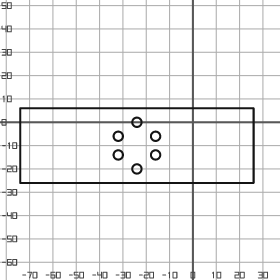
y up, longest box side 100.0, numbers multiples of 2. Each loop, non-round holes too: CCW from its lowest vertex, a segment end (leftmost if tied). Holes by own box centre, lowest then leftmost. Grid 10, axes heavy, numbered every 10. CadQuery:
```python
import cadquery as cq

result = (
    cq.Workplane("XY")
    .moveTo(-74.0, -26.0)
    .lineTo(26.0, -26.0)
    .lineTo(26.0, 6.0)
    .lineTo(-74.0, 6.0)
    .close()
    .moveTo(-24.0, -20.0)
    .circle(2.0)
    .moveTo(-32.0, -14.0)
    .circle(2.0)
    .moveTo(-16.0, -14.0)
    .circle(2.0)
    .moveTo(-32.0, -6.0)
    .circle(2.0)
    .moveTo(-16.0, -6.0)
    .circle(2.0)
    .moveTo(-24.0, 0.0)
    .circle(2.0)
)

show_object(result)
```